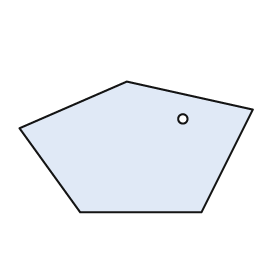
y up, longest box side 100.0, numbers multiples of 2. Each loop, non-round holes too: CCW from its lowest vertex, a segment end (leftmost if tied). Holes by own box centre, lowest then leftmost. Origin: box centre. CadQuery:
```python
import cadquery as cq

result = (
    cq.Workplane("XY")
    .moveTo(-24.0, -28.0)
    .lineTo(28.0, -28.0)
    .lineTo(50.0, 16.0)
    .lineTo(-4.0, 28.0)
    .lineTo(-50.0, 8.0)
    .close()
    .moveTo(20.0, 12.0)
    .circle(2.0)
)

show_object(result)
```